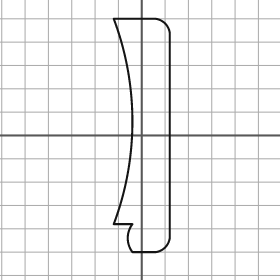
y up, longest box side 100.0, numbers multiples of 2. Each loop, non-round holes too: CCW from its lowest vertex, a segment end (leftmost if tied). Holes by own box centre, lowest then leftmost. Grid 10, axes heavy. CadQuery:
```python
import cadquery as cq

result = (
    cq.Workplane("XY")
    .moveTo(-4.0, -50.0)
    .lineTo(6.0, -50.0)
    .threePointArc((10.0, -48.0), (12.0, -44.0))
    .lineTo(12.0, 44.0)
    .threePointArc((10.0, 48.0), (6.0, 50.0))
    .lineTo(-12.0, 50.0)
    .threePointArc((-4.0, 6.0), (-12.0, -38.0))
    .lineTo(-4.0, -38.0)
    .threePointArc((-6.0, -44.0), (-4.0, -50.0))
    .close()
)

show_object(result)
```